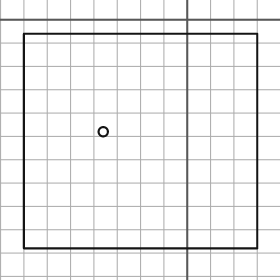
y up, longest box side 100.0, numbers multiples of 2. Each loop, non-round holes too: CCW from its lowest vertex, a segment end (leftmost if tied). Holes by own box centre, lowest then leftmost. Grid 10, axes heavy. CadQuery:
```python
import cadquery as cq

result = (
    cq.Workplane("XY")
    .moveTo(-70.0, -98.0)
    .lineTo(30.0, -98.0)
    .lineTo(30.0, -6.0)
    .lineTo(-70.0, -6.0)
    .close()
    .moveTo(-36.0, -48.0)
    .circle(2.0)
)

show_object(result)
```